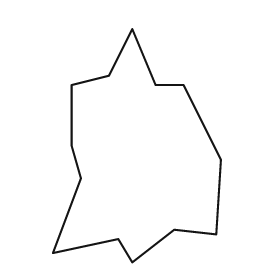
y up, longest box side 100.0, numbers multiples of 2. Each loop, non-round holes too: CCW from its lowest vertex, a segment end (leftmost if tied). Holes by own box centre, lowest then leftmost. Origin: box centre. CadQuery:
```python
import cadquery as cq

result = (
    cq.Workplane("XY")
    .moveTo(-2.0, -50.0)
    .lineTo(16.0, -36.0)
    .lineTo(34.0, -38.0)
    .lineTo(36.0, -6.0)
    .lineTo(20.0, 26.0)
    .lineTo(8.0, 26.0)
    .lineTo(-2.0, 50.0)
    .lineTo(-12.0, 30.0)
    .lineTo(-28.0, 26.0)
    .lineTo(-28.0, 0.0)
    .lineTo(-24.0, -14.0)
    .lineTo(-36.0, -46.0)
    .lineTo(-8.0, -40.0)
    .close()
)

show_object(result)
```